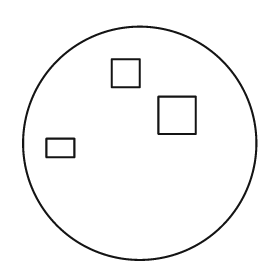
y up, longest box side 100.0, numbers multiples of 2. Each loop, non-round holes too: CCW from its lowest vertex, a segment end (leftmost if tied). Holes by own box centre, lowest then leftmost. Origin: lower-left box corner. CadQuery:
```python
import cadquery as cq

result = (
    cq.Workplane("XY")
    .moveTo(50.0, 50.0)
    .circle(50.0)
    .moveTo(10.0, 44.0)
    .lineTo(22.0, 44.0)
    .lineTo(22.0, 52.0)
    .lineTo(10.0, 52.0)
    .close()
    .moveTo(58.0, 54.0)
    .lineTo(74.0, 54.0)
    .lineTo(74.0, 70.0)
    .lineTo(58.0, 70.0)
    .close()
    .moveTo(38.0, 74.0)
    .lineTo(50.0, 74.0)
    .lineTo(50.0, 86.0)
    .lineTo(38.0, 86.0)
    .close()
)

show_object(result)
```